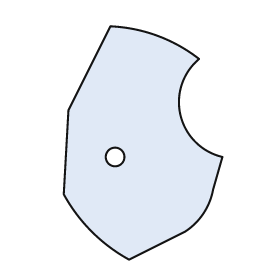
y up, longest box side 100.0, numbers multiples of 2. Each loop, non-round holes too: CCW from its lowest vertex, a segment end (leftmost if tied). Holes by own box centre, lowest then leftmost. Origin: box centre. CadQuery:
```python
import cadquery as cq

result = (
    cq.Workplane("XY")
    .moveTo(-6.0, -50.0)
    .lineTo(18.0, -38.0)
    .threePointArc((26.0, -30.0), (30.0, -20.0))
    .lineTo(34.0, -6.0)
    .threePointArc((16.0, 12.0), (24.0, 36.0))
    .threePointArc((6.0, 46.0), (-14.0, 50.0))
    .lineTo(-32.0, 14.0)
    .lineTo(-34.0, -22.0)
    .threePointArc((-22.0, -38.0), (-6.0, -50.0))
    .close()
    .moveTo(-12.0, -6.0)
    .circle(4.0)
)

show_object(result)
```